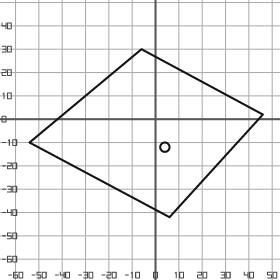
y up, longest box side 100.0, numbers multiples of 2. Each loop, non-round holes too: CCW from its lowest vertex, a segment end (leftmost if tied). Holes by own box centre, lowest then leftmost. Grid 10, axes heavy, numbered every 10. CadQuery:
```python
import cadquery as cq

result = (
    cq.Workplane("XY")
    .moveTo(6.0, -42.0)
    .lineTo(46.0, 2.0)
    .lineTo(-6.0, 30.0)
    .lineTo(-54.0, -10.0)
    .close()
    .moveTo(4.0, -12.0)
    .circle(2.0)
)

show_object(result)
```